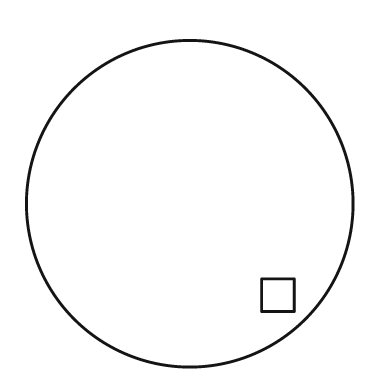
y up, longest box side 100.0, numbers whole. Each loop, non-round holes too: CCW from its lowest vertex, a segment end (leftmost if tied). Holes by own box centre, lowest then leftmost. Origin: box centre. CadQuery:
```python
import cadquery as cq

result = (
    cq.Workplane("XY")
    .moveTo(0.0, 0.0)
    .circle(50.0)
    .moveTo(22.0, -33.0)
    .lineTo(32.0, -33.0)
    .lineTo(32.0, -23.0)
    .lineTo(22.0, -23.0)
    .close()
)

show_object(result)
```